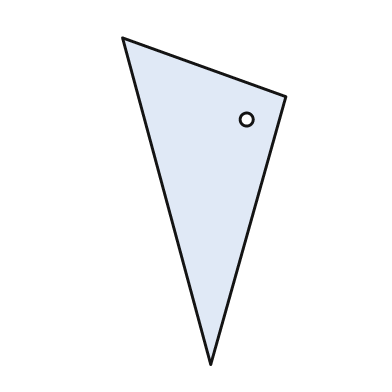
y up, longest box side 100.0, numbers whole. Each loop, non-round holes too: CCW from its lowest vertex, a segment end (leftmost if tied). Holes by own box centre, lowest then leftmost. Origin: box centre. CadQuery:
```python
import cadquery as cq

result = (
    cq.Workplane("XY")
    .moveTo(2.0, -50.0)
    .lineTo(25.0, 32.0)
    .lineTo(-25.0, 50.0)
    .close()
    .moveTo(13.0, 25.0)
    .circle(2.0)
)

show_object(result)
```